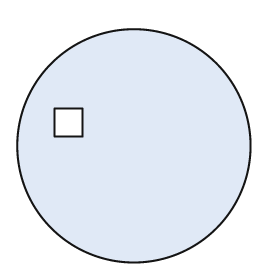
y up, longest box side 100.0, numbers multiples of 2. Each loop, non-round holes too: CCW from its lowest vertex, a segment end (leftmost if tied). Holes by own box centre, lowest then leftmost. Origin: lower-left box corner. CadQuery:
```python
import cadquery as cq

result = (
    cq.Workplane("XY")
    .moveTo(50.0, 50.0)
    .circle(50.0)
    .moveTo(16.0, 54.0)
    .lineTo(28.0, 54.0)
    .lineTo(28.0, 66.0)
    .lineTo(16.0, 66.0)
    .close()
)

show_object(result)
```